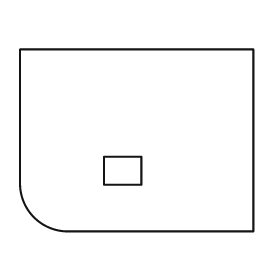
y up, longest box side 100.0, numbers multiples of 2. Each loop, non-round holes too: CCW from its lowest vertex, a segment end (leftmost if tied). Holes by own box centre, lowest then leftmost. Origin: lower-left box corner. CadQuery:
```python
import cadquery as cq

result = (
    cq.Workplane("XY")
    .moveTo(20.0, 0.0)
    .lineTo(100.0, 0.0)
    .lineTo(100.0, 78.0)
    .lineTo(0.0, 78.0)
    .lineTo(0.0, 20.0)
    .threePointArc((6.0, 6.0), (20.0, 0.0))
    .close()
    .moveTo(36.0, 20.0)
    .lineTo(52.0, 20.0)
    .lineTo(52.0, 32.0)
    .lineTo(36.0, 32.0)
    .close()
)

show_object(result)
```